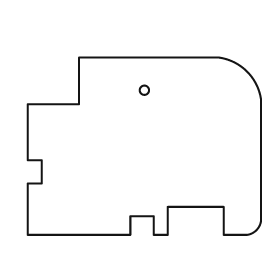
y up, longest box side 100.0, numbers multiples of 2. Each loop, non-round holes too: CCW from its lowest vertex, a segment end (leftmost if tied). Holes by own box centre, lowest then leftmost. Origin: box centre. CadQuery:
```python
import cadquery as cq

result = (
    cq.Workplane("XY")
    .moveTo(-50.0, -38.0)
    .lineTo(-6.0, -38.0)
    .lineTo(-6.0, -30.0)
    .lineTo(4.0, -30.0)
    .lineTo(4.0, -38.0)
    .lineTo(10.0, -38.0)
    .lineTo(10.0, -26.0)
    .lineTo(34.0, -26.0)
    .lineTo(34.0, -38.0)
    .lineTo(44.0, -38.0)
    .threePointArc((48.0, -36.0), (50.0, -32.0))
    .lineTo(50.0, 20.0)
    .threePointArc((44.0, 32.0), (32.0, 38.0))
    .lineTo(-28.0, 38.0)
    .lineTo(-28.0, 18.0)
    .lineTo(-50.0, 18.0)
    .lineTo(-50.0, -6.0)
    .lineTo(-44.0, -6.0)
    .lineTo(-44.0, -16.0)
    .lineTo(-50.0, -16.0)
    .close()
    .moveTo(0.0, 24.0)
    .circle(2.0)
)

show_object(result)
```